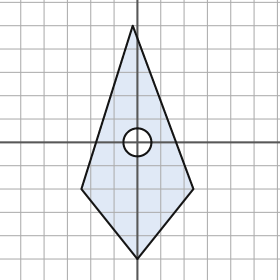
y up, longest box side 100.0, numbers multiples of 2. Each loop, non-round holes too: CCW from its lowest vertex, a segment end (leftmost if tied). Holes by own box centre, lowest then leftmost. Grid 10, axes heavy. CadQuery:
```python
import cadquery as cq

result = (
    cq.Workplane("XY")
    .moveTo(0.0, -50.0)
    .lineTo(24.0, -20.0)
    .lineTo(-2.0, 50.0)
    .lineTo(-24.0, -20.0)
    .close()
    .moveTo(0.0, 0.0)
    .circle(6.0)
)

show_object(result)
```